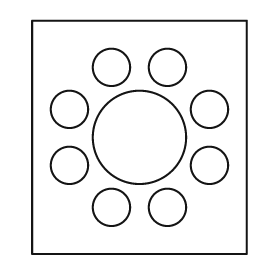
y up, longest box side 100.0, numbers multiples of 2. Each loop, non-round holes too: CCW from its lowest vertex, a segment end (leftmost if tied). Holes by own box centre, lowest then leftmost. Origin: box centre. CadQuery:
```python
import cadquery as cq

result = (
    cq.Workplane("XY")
    .moveTo(-46.0, -50.0)
    .lineTo(46.0, -50.0)
    .lineTo(46.0, 50.0)
    .lineTo(-46.0, 50.0)
    .close()
    .moveTo(-12.0, -30.0)
    .circle(8.0)
    .moveTo(12.0, -30.0)
    .circle(8.0)
    .moveTo(-30.0, -12.0)
    .circle(8.0)
    .moveTo(30.0, -12.0)
    .circle(8.0)
    .moveTo(0.0, 0.0)
    .circle(20.0)
    .moveTo(-30.0, 12.0)
    .circle(8.0)
    .moveTo(30.0, 12.0)
    .circle(8.0)
    .moveTo(-12.0, 30.0)
    .circle(8.0)
    .moveTo(12.0, 30.0)
    .circle(8.0)
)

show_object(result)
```